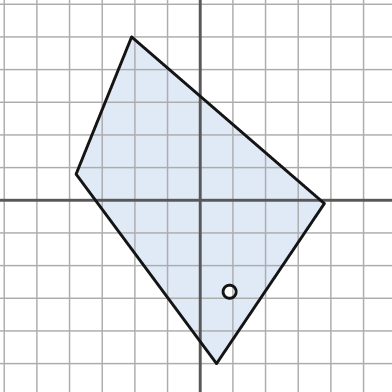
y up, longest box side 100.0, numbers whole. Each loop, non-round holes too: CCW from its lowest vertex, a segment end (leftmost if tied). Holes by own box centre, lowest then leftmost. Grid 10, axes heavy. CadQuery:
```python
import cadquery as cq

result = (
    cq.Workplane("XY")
    .moveTo(5.0, -50.0)
    .lineTo(38.0, -1.0)
    .lineTo(-21.0, 50.0)
    .lineTo(-38.0, 8.0)
    .close()
    .moveTo(9.0, -28.0)
    .circle(2.0)
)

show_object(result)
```